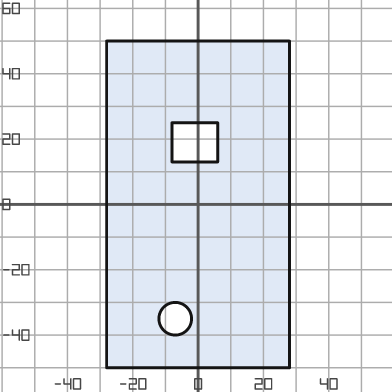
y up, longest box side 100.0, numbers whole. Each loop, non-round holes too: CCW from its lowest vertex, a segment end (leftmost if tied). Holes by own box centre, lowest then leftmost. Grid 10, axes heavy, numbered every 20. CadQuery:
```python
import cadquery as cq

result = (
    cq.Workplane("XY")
    .moveTo(-28.0, -50.0)
    .lineTo(28.0, -50.0)
    .lineTo(28.0, 50.0)
    .lineTo(-28.0, 50.0)
    .close()
    .moveTo(-7.0, -35.0)
    .circle(5.0)
    .moveTo(-8.0, 13.0)
    .lineTo(6.0, 13.0)
    .lineTo(6.0, 25.0)
    .lineTo(-8.0, 25.0)
    .close()
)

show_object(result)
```